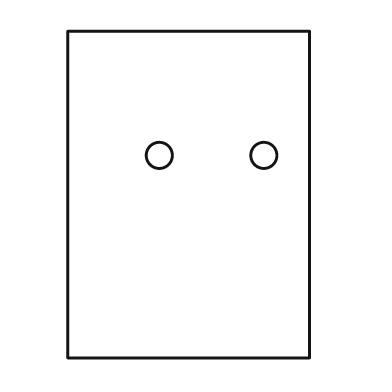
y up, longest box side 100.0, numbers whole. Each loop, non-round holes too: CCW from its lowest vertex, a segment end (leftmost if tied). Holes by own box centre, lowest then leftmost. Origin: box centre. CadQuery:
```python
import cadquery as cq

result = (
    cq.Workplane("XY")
    .moveTo(-37.0, -50.0)
    .lineTo(37.0, -50.0)
    .lineTo(37.0, 50.0)
    .lineTo(-37.0, 50.0)
    .close()
    .moveTo(-9.0, 12.0)
    .circle(4.0)
    .moveTo(23.0, 12.0)
    .circle(4.0)
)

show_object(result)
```